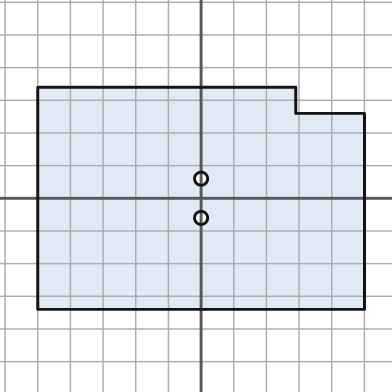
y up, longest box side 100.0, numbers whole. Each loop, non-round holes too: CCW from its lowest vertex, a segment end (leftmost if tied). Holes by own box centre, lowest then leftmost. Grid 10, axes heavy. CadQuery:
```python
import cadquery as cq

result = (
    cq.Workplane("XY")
    .moveTo(-50.0, -34.0)
    .lineTo(50.0, -34.0)
    .lineTo(50.0, 26.0)
    .lineTo(29.0, 26.0)
    .lineTo(29.0, 34.0)
    .lineTo(-50.0, 34.0)
    .close()
    .moveTo(0.0, -6.0)
    .circle(2.0)
    .moveTo(0.0, 6.0)
    .circle(2.0)
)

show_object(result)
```